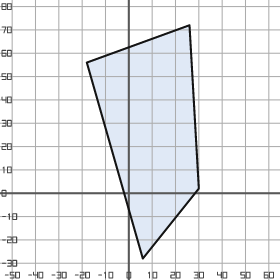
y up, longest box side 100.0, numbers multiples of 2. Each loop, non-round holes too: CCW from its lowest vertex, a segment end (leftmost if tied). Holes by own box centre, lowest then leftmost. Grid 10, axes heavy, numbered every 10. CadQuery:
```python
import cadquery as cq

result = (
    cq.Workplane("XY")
    .moveTo(6.0, -28.0)
    .lineTo(30.0, 2.0)
    .lineTo(26.0, 72.0)
    .lineTo(-18.0, 56.0)
    .close()
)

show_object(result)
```